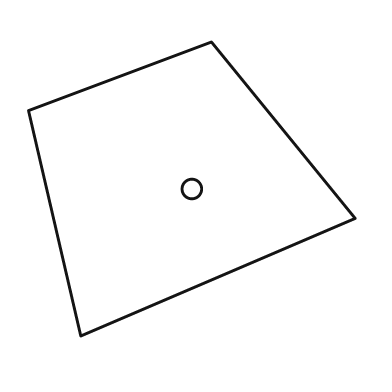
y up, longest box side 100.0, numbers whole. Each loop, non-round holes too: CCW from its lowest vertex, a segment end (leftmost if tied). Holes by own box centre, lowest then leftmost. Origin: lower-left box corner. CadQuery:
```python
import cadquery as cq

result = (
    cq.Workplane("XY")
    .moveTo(16.0, 0.0)
    .lineTo(100.0, 36.0)
    .lineTo(56.0, 90.0)
    .lineTo(0.0, 69.0)
    .close()
    .moveTo(50.0, 45.0)
    .circle(3.0)
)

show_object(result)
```